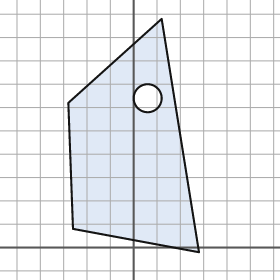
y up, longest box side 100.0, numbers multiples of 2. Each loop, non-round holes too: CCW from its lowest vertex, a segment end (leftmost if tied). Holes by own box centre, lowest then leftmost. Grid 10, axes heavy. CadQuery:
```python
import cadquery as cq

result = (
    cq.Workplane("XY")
    .moveTo(28.0, -2.0)
    .lineTo(12.0, 98.0)
    .lineTo(-28.0, 62.0)
    .lineTo(-26.0, 8.0)
    .close()
    .moveTo(6.0, 64.0)
    .circle(6.0)
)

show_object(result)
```